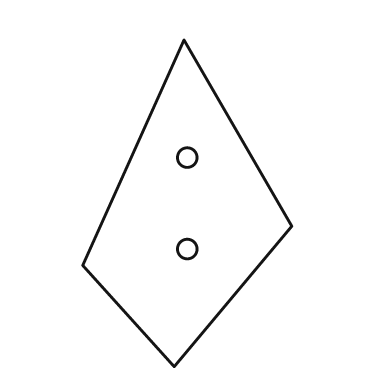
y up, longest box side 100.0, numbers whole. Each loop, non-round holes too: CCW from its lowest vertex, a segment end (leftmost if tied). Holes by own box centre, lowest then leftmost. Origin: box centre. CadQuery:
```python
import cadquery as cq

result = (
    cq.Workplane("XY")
    .moveTo(-4.0, -50.0)
    .lineTo(32.0, -7.0)
    .lineTo(-1.0, 50.0)
    .lineTo(-32.0, -19.0)
    .close()
    .moveTo(0.0, -14.0)
    .circle(3.0)
    .moveTo(0.0, 14.0)
    .circle(3.0)
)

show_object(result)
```